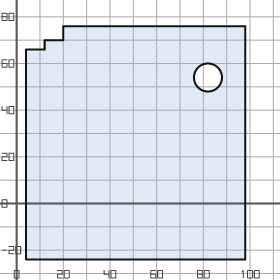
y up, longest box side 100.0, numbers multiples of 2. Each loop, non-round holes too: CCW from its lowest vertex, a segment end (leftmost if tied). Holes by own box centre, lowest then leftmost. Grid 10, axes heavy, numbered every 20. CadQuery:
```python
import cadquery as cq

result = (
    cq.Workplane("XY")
    .moveTo(4.0, -24.0)
    .lineTo(98.0, -24.0)
    .lineTo(98.0, 76.0)
    .lineTo(20.0, 76.0)
    .lineTo(20.0, 70.0)
    .lineTo(12.0, 70.0)
    .lineTo(12.0, 66.0)
    .lineTo(4.0, 66.0)
    .close()
    .moveTo(82.0, 54.0)
    .circle(6.0)
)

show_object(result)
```